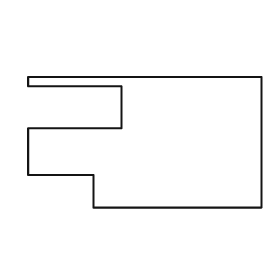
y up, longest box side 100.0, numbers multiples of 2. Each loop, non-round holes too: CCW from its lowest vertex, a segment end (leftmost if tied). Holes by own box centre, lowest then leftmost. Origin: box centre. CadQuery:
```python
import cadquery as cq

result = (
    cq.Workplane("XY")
    .moveTo(-22.0, -28.0)
    .lineTo(50.0, -28.0)
    .lineTo(50.0, 28.0)
    .lineTo(-50.0, 28.0)
    .lineTo(-50.0, 24.0)
    .lineTo(-10.0, 24.0)
    .lineTo(-10.0, 6.0)
    .lineTo(-50.0, 6.0)
    .lineTo(-50.0, -14.0)
    .lineTo(-22.0, -14.0)
    .close()
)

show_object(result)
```